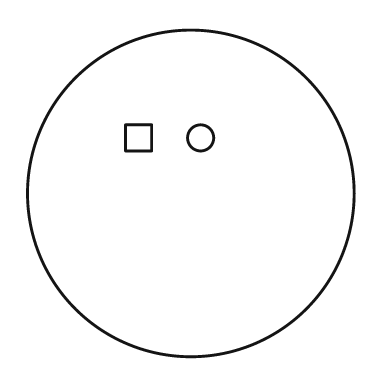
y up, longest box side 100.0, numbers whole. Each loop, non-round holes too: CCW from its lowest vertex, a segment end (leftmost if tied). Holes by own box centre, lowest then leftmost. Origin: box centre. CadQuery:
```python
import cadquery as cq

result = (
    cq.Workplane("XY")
    .moveTo(0.0, 0.0)
    .circle(50.0)
    .moveTo(-20.0, 13.0)
    .lineTo(-12.0, 13.0)
    .lineTo(-12.0, 21.0)
    .lineTo(-20.0, 21.0)
    .close()
    .moveTo(3.0, 17.0)
    .circle(4.0)
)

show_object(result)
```